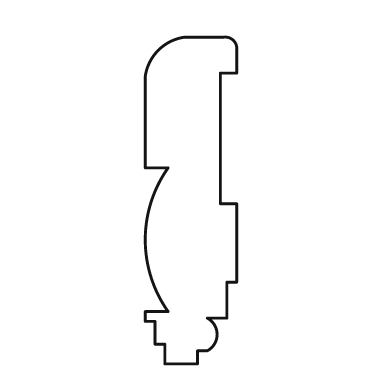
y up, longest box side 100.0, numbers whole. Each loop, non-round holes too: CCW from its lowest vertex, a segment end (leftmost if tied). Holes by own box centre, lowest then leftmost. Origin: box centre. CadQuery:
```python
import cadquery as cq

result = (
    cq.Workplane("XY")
    .moveTo(-8.0, -50.0)
    .lineTo(2.0, -50.0)
    .lineTo(2.0, -46.0)
    .lineTo(5.0, -46.0)
    .threePointArc((8.0, -41.0), (5.0, -36.0))
    .lineTo(11.0, -36.0)
    .lineTo(11.0, -25.0)
    .lineTo(14.0, -25.0)
    .lineTo(14.0, -1.0)
    .lineTo(9.0, -1.0)
    .lineTo(9.0, 39.0)
    .lineTo(14.0, 39.0)
    .lineTo(14.0, 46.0)
    .threePointArc((13.0, 49.0), (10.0, 50.0))
    .lineTo(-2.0, 50.0)
    .threePointArc((-10.0, 46.0), (-14.0, 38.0))
    .lineTo(-14.0, 10.0)
    .lineTo(-7.0, 10.0)
    .threePointArc((-14.0, -12.0), (-7.0, -34.0))
    .lineTo(-14.0, -34.0)
    .lineTo(-14.0, -37.0)
    .lineTo(-11.0, -37.0)
    .lineTo(-11.0, -44.0)
    .lineTo(-8.0, -44.0)
    .close()
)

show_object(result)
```